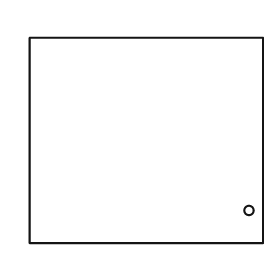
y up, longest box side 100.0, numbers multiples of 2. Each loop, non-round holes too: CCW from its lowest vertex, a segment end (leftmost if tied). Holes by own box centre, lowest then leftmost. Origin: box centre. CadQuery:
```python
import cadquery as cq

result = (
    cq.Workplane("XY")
    .moveTo(-50.0, -44.0)
    .lineTo(50.0, -44.0)
    .lineTo(50.0, 44.0)
    .lineTo(-50.0, 44.0)
    .close()
    .moveTo(44.0, -30.0)
    .circle(2.0)
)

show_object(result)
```